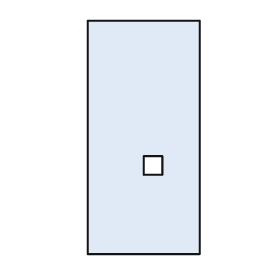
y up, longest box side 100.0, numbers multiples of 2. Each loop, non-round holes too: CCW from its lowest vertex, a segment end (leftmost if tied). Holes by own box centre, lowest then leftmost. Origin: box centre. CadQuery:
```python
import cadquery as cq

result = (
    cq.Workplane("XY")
    .moveTo(-24.0, -50.0)
    .lineTo(24.0, -50.0)
    .lineTo(24.0, 50.0)
    .lineTo(-24.0, 50.0)
    .close()
    .moveTo(0.0, -16.0)
    .lineTo(8.0, -16.0)
    .lineTo(8.0, -8.0)
    .lineTo(0.0, -8.0)
    .close()
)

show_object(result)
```